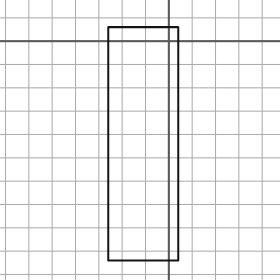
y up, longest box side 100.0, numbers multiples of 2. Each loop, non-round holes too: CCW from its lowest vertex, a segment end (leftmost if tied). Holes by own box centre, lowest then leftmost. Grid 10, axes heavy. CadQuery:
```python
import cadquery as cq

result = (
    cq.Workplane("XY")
    .moveTo(-26.0, -94.0)
    .lineTo(4.0, -94.0)
    .lineTo(4.0, 6.0)
    .lineTo(-26.0, 6.0)
    .close()
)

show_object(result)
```